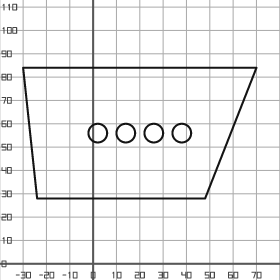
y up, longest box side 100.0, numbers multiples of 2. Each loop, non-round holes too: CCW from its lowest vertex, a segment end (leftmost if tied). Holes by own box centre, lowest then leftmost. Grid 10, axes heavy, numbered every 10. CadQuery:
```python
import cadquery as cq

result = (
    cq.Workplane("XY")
    .moveTo(-24.0, 28.0)
    .lineTo(48.0, 28.0)
    .lineTo(70.0, 84.0)
    .lineTo(-30.0, 84.0)
    .close()
    .moveTo(2.0, 56.0)
    .circle(4.0)
    .moveTo(14.0, 56.0)
    .circle(4.0)
    .moveTo(26.0, 56.0)
    .circle(4.0)
    .moveTo(38.0, 56.0)
    .circle(4.0)
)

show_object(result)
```